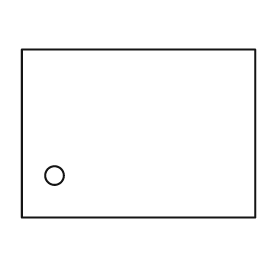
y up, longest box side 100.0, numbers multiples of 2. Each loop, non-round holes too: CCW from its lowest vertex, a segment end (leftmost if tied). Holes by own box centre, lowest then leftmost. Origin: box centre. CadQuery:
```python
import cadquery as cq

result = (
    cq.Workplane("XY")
    .moveTo(-50.0, -36.0)
    .lineTo(50.0, -36.0)
    .lineTo(50.0, 36.0)
    .lineTo(-50.0, 36.0)
    .close()
    .moveTo(-36.0, -18.0)
    .circle(4.0)
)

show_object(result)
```